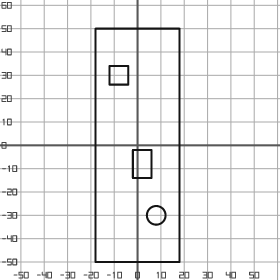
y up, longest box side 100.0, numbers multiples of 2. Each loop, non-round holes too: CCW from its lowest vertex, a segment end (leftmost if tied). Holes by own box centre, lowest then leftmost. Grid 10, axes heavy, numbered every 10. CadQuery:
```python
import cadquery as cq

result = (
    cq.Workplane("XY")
    .moveTo(-18.0, -50.0)
    .lineTo(18.0, -50.0)
    .lineTo(18.0, 50.0)
    .lineTo(-18.0, 50.0)
    .close()
    .moveTo(8.0, -30.0)
    .circle(4.0)
    .moveTo(-2.0, -14.0)
    .lineTo(6.0, -14.0)
    .lineTo(6.0, -2.0)
    .lineTo(-2.0, -2.0)
    .close()
    .moveTo(-12.0, 26.0)
    .lineTo(-4.0, 26.0)
    .lineTo(-4.0, 34.0)
    .lineTo(-12.0, 34.0)
    .close()
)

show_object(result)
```